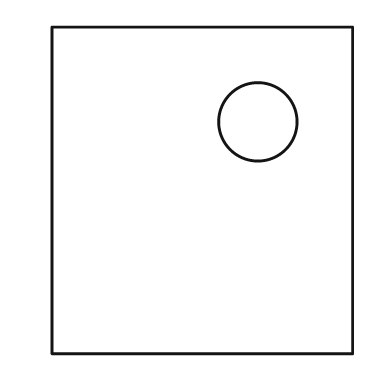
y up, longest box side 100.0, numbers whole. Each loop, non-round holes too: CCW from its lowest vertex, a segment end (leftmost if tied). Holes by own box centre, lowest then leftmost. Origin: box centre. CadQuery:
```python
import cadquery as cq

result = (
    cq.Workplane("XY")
    .moveTo(-46.0, -50.0)
    .lineTo(46.0, -50.0)
    .lineTo(46.0, 50.0)
    .lineTo(-46.0, 50.0)
    .close()
    .moveTo(17.0, 21.0)
    .circle(12.0)
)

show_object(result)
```